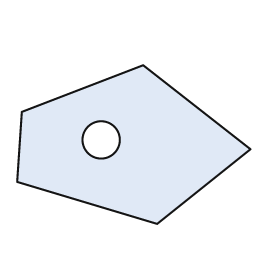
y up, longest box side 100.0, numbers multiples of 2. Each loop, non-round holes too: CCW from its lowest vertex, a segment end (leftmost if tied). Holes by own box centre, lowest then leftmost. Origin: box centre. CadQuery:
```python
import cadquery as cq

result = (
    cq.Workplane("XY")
    .moveTo(10.0, -34.0)
    .lineTo(50.0, -2.0)
    .lineTo(4.0, 34.0)
    .lineTo(-48.0, 14.0)
    .lineTo(-50.0, -16.0)
    .close()
    .moveTo(-14.0, 2.0)
    .circle(8.0)
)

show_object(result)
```